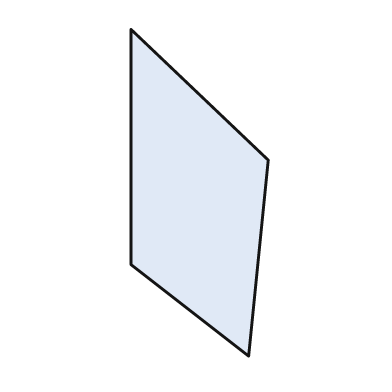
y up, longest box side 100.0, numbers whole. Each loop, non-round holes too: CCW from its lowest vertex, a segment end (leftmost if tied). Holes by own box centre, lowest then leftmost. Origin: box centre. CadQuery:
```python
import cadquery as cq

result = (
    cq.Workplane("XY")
    .moveTo(15.0, -50.0)
    .lineTo(21.0, 10.0)
    .lineTo(-21.0, 50.0)
    .lineTo(-21.0, -22.0)
    .close()
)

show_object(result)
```